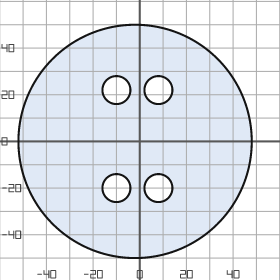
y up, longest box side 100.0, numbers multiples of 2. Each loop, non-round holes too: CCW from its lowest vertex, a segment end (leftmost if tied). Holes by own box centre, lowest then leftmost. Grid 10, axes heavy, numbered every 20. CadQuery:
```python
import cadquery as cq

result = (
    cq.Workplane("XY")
    .moveTo(-2.0, 0.0)
    .circle(50.0)
    .moveTo(-10.0, -20.0)
    .circle(6.0)
    .moveTo(8.0, -20.0)
    .circle(6.0)
    .moveTo(-10.0, 22.0)
    .circle(6.0)
    .moveTo(8.0, 22.0)
    .circle(6.0)
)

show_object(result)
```